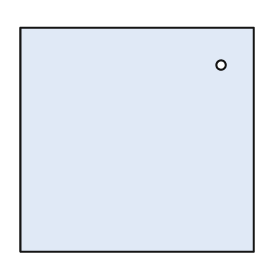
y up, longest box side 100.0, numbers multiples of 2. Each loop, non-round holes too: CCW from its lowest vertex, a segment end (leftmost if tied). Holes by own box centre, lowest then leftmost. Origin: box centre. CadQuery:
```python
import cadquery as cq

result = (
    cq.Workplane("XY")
    .moveTo(-50.0, -48.0)
    .lineTo(50.0, -48.0)
    .lineTo(50.0, 48.0)
    .lineTo(-50.0, 48.0)
    .close()
    .moveTo(36.0, 32.0)
    .circle(2.0)
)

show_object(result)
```